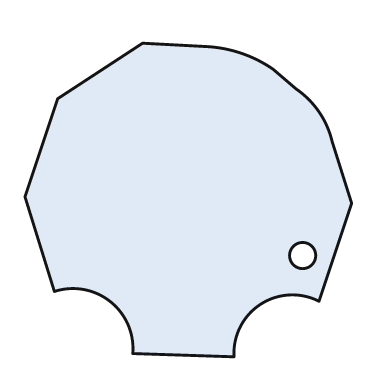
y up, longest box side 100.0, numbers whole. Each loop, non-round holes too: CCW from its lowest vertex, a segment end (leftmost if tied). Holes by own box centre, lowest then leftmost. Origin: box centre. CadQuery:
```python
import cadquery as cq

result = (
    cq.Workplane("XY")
    .moveTo(14.0, -48.0)
    .threePointArc((22.0, -32.0), (40.0, -31.0))
    .lineTo(50.0, -1.0)
    .lineTo(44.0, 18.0)
    .threePointArc((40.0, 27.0), (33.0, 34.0))
    .lineTo(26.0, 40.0)
    .threePointArc((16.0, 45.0), (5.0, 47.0))
    .lineTo(-14.0, 48.0)
    .lineTo(-40.0, 31.0)
    .lineTo(-50.0, 1.0)
    .lineTo(-41.0, -28.0)
    .threePointArc((-24.0, -31.0), (-17.0, -47.0))
    .close()
    .moveTo(35.0, -17.0)
    .circle(4.0)
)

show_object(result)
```